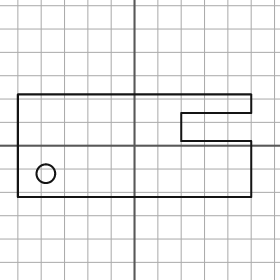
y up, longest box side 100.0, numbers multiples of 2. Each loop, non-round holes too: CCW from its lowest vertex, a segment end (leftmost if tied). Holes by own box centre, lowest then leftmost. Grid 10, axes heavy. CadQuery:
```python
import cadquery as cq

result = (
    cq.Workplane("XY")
    .moveTo(-50.0, -22.0)
    .lineTo(50.0, -22.0)
    .lineTo(50.0, 2.0)
    .lineTo(20.0, 2.0)
    .lineTo(20.0, 14.0)
    .lineTo(50.0, 14.0)
    .lineTo(50.0, 22.0)
    .lineTo(-50.0, 22.0)
    .close()
    .moveTo(-38.0, -12.0)
    .circle(4.0)
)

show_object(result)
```